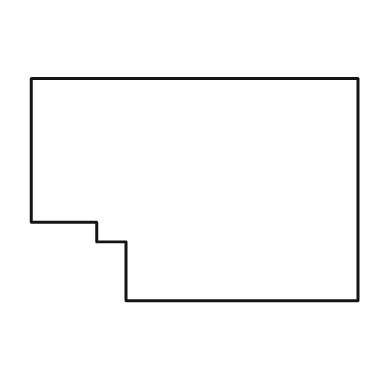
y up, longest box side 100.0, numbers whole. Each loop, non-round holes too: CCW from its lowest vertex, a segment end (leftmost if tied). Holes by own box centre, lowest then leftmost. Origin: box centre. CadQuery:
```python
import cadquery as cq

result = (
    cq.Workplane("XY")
    .moveTo(-21.0, -34.0)
    .lineTo(50.0, -34.0)
    .lineTo(50.0, 34.0)
    .lineTo(-50.0, 34.0)
    .lineTo(-50.0, -10.0)
    .lineTo(-30.0, -10.0)
    .lineTo(-30.0, -16.0)
    .lineTo(-21.0, -16.0)
    .close()
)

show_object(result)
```